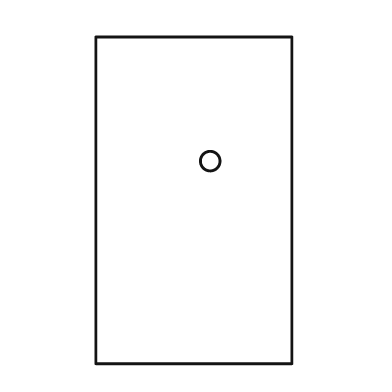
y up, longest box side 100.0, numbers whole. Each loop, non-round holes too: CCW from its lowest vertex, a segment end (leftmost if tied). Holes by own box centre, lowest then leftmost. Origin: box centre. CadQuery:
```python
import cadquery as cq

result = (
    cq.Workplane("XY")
    .moveTo(-30.0, -50.0)
    .lineTo(30.0, -50.0)
    .lineTo(30.0, 50.0)
    .lineTo(-30.0, 50.0)
    .close()
    .moveTo(5.0, 12.0)
    .circle(3.0)
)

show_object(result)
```